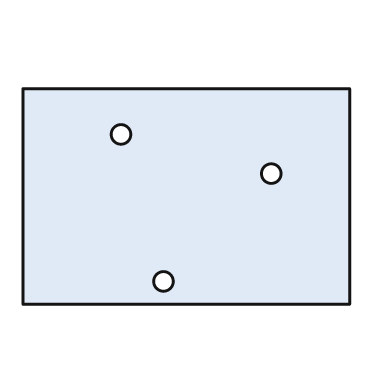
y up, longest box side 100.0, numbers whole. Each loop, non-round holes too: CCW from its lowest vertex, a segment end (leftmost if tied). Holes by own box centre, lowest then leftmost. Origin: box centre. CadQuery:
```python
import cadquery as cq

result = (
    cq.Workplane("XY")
    .moveTo(-50.0, -33.0)
    .lineTo(50.0, -33.0)
    .lineTo(50.0, 33.0)
    .lineTo(-50.0, 33.0)
    .close()
    .moveTo(-7.0, -26.0)
    .circle(3.0)
    .moveTo(26.0, 7.0)
    .circle(3.0)
    .moveTo(-20.0, 19.0)
    .circle(3.0)
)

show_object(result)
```